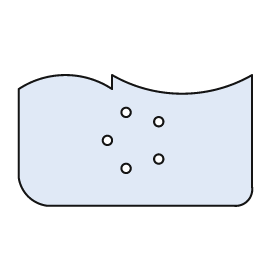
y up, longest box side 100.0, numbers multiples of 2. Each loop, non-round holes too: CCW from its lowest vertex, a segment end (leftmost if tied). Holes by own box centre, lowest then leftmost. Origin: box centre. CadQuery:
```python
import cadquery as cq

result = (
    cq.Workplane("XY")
    .moveTo(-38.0, -28.0)
    .lineTo(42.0, -28.0)
    .threePointArc((48.0, -26.0), (50.0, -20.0))
    .lineTo(50.0, 28.0)
    .threePointArc((20.0, 20.0), (-10.0, 28.0))
    .lineTo(-10.0, 22.0)
    .threePointArc((-30.0, 28.0), (-50.0, 22.0))
    .lineTo(-50.0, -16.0)
    .threePointArc((-46.0, -24.0), (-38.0, -28.0))
    .close()
    .moveTo(-4.0, -12.0)
    .circle(2.0)
    .moveTo(10.0, -8.0)
    .circle(2.0)
    .moveTo(-12.0, 0.0)
    .circle(2.0)
    .moveTo(10.0, 8.0)
    .circle(2.0)
    .moveTo(-4.0, 12.0)
    .circle(2.0)
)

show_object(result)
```